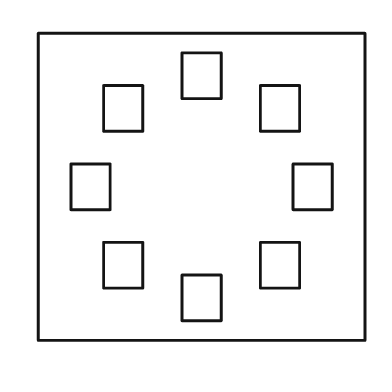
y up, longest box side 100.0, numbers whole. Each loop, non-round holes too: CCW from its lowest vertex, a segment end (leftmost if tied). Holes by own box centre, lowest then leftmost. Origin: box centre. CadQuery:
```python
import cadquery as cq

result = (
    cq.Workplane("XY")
    .moveTo(-50.0, -47.0)
    .lineTo(50.0, -47.0)
    .lineTo(50.0, 47.0)
    .lineTo(-50.0, 47.0)
    .close()
    .moveTo(-6.0, -41.0)
    .lineTo(6.0, -41.0)
    .lineTo(6.0, -27.0)
    .lineTo(-6.0, -27.0)
    .close()
    .moveTo(-30.0, -31.0)
    .lineTo(-18.0, -31.0)
    .lineTo(-18.0, -17.0)
    .lineTo(-30.0, -17.0)
    .close()
    .moveTo(18.0, -31.0)
    .lineTo(30.0, -31.0)
    .lineTo(30.0, -17.0)
    .lineTo(18.0, -17.0)
    .close()
    .moveTo(-40.0, -7.0)
    .lineTo(-28.0, -7.0)
    .lineTo(-28.0, 7.0)
    .lineTo(-40.0, 7.0)
    .close()
    .moveTo(28.0, -7.0)
    .lineTo(40.0, -7.0)
    .lineTo(40.0, 7.0)
    .lineTo(28.0, 7.0)
    .close()
    .moveTo(-30.0, 17.0)
    .lineTo(-18.0, 17.0)
    .lineTo(-18.0, 31.0)
    .lineTo(-30.0, 31.0)
    .close()
    .moveTo(18.0, 17.0)
    .lineTo(30.0, 17.0)
    .lineTo(30.0, 31.0)
    .lineTo(18.0, 31.0)
    .close()
    .moveTo(-6.0, 27.0)
    .lineTo(6.0, 27.0)
    .lineTo(6.0, 41.0)
    .lineTo(-6.0, 41.0)
    .close()
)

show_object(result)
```